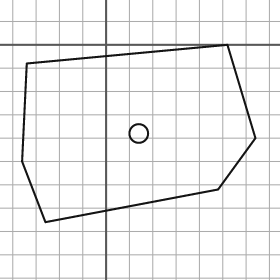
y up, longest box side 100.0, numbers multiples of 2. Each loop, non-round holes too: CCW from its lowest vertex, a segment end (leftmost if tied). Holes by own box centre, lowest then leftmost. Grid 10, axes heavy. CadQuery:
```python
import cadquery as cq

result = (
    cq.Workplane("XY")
    .moveTo(-26.0, -76.0)
    .lineTo(48.0, -62.0)
    .lineTo(64.0, -40.0)
    .lineTo(52.0, 0.0)
    .lineTo(-34.0, -8.0)
    .lineTo(-36.0, -50.0)
    .close()
    .moveTo(14.0, -38.0)
    .circle(4.0)
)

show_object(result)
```